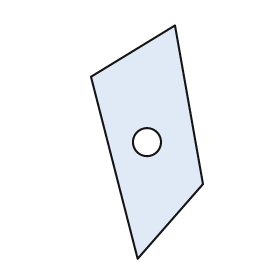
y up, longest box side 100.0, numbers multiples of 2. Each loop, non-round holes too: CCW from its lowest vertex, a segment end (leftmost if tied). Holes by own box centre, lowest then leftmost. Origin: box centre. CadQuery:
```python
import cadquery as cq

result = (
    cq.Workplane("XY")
    .moveTo(-4.0, -50.0)
    .lineTo(24.0, -18.0)
    .lineTo(12.0, 50.0)
    .lineTo(-24.0, 28.0)
    .close()
    .moveTo(0.0, 0.0)
    .circle(6.0)
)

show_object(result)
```